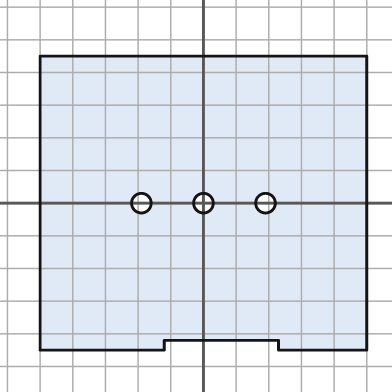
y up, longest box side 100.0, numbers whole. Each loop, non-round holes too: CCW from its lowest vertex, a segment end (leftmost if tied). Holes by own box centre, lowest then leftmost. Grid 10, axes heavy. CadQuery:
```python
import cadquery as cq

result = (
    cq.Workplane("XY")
    .moveTo(-50.0, -45.0)
    .lineTo(-12.0, -45.0)
    .lineTo(-12.0, -42.0)
    .lineTo(23.0, -42.0)
    .lineTo(23.0, -45.0)
    .lineTo(50.0, -45.0)
    .lineTo(50.0, 45.0)
    .lineTo(-50.0, 45.0)
    .close()
    .moveTo(-19.0, 0.0)
    .circle(3.0)
    .moveTo(0.0, 0.0)
    .circle(3.0)
    .moveTo(19.0, 0.0)
    .circle(3.0)
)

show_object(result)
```